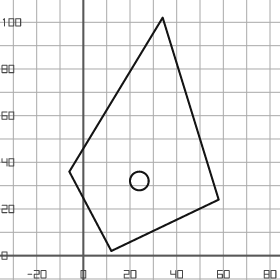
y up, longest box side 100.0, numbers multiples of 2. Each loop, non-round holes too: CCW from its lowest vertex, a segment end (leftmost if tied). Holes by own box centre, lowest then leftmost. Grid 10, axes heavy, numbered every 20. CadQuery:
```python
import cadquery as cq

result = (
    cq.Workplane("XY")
    .moveTo(12.0, 2.0)
    .lineTo(58.0, 24.0)
    .lineTo(34.0, 102.0)
    .lineTo(-6.0, 36.0)
    .close()
    .moveTo(24.0, 32.0)
    .circle(4.0)
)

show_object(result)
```